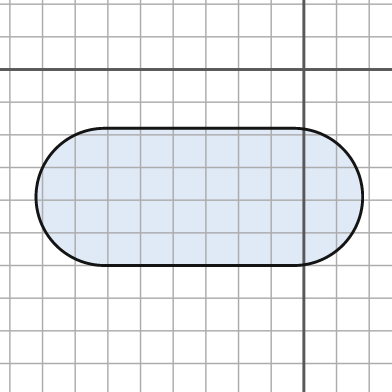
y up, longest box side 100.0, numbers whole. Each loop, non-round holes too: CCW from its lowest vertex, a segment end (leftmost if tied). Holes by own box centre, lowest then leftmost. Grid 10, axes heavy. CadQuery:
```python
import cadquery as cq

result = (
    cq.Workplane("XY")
    .moveTo(-61.0, -60.0)
    .lineTo(-3.0, -60.0)
    .threePointArc((18.0, -39.0), (-3.0, -18.0))
    .lineTo(-61.0, -18.0)
    .threePointArc((-82.0, -39.0), (-61.0, -60.0))
    .close()
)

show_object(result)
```